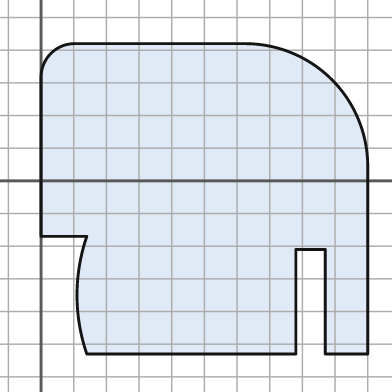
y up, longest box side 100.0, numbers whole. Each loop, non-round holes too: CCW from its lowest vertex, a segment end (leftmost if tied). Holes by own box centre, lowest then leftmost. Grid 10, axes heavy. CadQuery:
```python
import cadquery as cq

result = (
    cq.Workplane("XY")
    .moveTo(14.0, -53.0)
    .lineTo(78.0, -53.0)
    .lineTo(78.0, -21.0)
    .lineTo(87.0, -21.0)
    .lineTo(87.0, -53.0)
    .lineTo(100.0, -53.0)
    .lineTo(100.0, 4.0)
    .threePointArc((89.0, 31.0), (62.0, 42.0))
    .lineTo(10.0, 42.0)
    .threePointArc((3.0, 39.0), (0.0, 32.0))
    .lineTo(0.0, -17.0)
    .lineTo(14.0, -17.0)
    .threePointArc((11.0, -35.0), (14.0, -53.0))
    .close()
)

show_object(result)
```